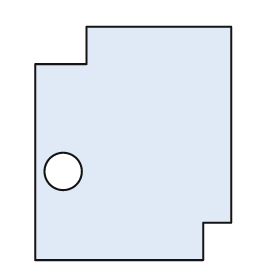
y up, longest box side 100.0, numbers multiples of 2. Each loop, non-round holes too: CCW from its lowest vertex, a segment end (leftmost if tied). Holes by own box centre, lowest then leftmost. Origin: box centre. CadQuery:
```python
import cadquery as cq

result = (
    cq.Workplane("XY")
    .moveTo(-42.0, -50.0)
    .lineTo(30.0, -50.0)
    .lineTo(30.0, -34.0)
    .lineTo(42.0, -34.0)
    .lineTo(42.0, 50.0)
    .lineTo(-20.0, 50.0)
    .lineTo(-20.0, 34.0)
    .lineTo(-42.0, 34.0)
    .close()
    .moveTo(-30.0, -12.0)
    .circle(8.0)
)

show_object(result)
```